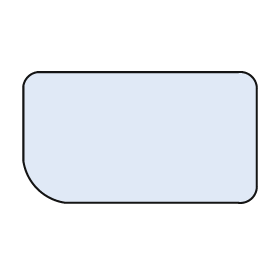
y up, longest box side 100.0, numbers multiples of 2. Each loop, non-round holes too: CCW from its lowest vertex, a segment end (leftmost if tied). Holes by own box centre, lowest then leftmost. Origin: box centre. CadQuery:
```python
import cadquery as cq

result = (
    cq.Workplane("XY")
    .moveTo(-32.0, -28.0)
    .lineTo(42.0, -28.0)
    .threePointArc((48.0, -26.0), (50.0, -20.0))
    .lineTo(50.0, 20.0)
    .threePointArc((48.0, 26.0), (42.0, 28.0))
    .lineTo(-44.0, 28.0)
    .threePointArc((-48.0, 26.0), (-50.0, 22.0))
    .lineTo(-50.0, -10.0)
    .threePointArc((-44.0, -22.0), (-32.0, -28.0))
    .close()
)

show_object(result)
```